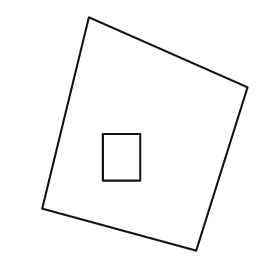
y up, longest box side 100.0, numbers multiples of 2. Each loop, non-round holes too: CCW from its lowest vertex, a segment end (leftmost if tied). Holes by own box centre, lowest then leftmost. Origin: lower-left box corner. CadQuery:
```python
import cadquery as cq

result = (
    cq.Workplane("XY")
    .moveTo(66.0, 0.0)
    .lineTo(88.0, 70.0)
    .lineTo(20.0, 100.0)
    .lineTo(0.0, 18.0)
    .close()
    .moveTo(26.0, 30.0)
    .lineTo(42.0, 30.0)
    .lineTo(42.0, 50.0)
    .lineTo(26.0, 50.0)
    .close()
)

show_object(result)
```